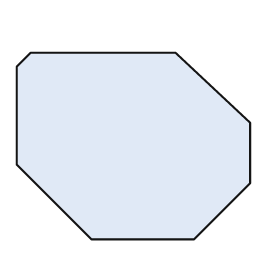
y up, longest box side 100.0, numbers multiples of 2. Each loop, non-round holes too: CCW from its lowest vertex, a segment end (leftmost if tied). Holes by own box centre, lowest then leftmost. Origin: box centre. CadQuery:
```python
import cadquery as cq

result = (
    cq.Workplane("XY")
    .moveTo(-18.0, -40.0)
    .lineTo(26.0, -40.0)
    .lineTo(50.0, -16.0)
    .lineTo(50.0, 10.0)
    .lineTo(18.0, 40.0)
    .lineTo(-44.0, 40.0)
    .lineTo(-50.0, 34.0)
    .lineTo(-50.0, -8.0)
    .close()
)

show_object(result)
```